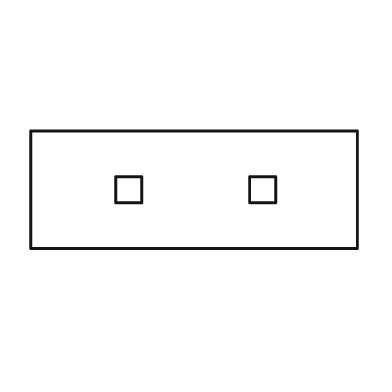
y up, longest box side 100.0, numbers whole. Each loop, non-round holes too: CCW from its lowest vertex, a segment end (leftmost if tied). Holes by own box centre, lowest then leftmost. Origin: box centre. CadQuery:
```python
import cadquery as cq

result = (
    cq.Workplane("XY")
    .moveTo(-50.0, -18.0)
    .lineTo(50.0, -18.0)
    .lineTo(50.0, 18.0)
    .lineTo(-50.0, 18.0)
    .close()
    .moveTo(-24.0, -4.0)
    .lineTo(-16.0, -4.0)
    .lineTo(-16.0, 4.0)
    .lineTo(-24.0, 4.0)
    .close()
    .moveTo(17.0, -4.0)
    .lineTo(25.0, -4.0)
    .lineTo(25.0, 4.0)
    .lineTo(17.0, 4.0)
    .close()
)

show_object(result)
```